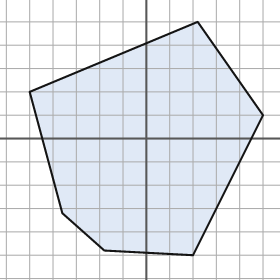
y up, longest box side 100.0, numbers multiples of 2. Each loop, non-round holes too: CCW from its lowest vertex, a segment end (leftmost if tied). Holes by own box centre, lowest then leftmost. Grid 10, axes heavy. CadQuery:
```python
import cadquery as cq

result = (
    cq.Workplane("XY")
    .moveTo(20.0, -50.0)
    .lineTo(50.0, 10.0)
    .lineTo(22.0, 50.0)
    .lineTo(-50.0, 20.0)
    .lineTo(-36.0, -32.0)
    .lineTo(-18.0, -48.0)
    .close()
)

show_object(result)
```